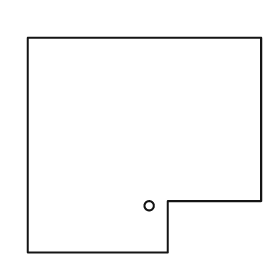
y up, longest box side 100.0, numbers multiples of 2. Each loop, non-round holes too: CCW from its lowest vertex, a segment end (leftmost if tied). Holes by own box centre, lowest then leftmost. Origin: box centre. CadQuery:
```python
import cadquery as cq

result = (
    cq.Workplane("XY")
    .moveTo(-50.0, -46.0)
    .lineTo(10.0, -46.0)
    .lineTo(10.0, -24.0)
    .lineTo(50.0, -24.0)
    .lineTo(50.0, 46.0)
    .lineTo(-50.0, 46.0)
    .close()
    .moveTo(2.0, -26.0)
    .circle(2.0)
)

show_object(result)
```